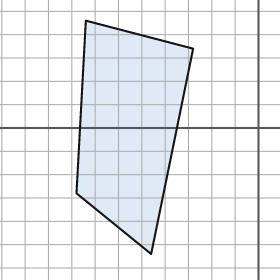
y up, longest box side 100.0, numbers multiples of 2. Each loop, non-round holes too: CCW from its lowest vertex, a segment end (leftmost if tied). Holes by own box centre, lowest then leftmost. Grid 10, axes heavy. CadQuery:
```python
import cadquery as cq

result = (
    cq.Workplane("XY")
    .moveTo(-46.0, -54.0)
    .lineTo(-28.0, 34.0)
    .lineTo(-74.0, 46.0)
    .lineTo(-78.0, -28.0)
    .close()
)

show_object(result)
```